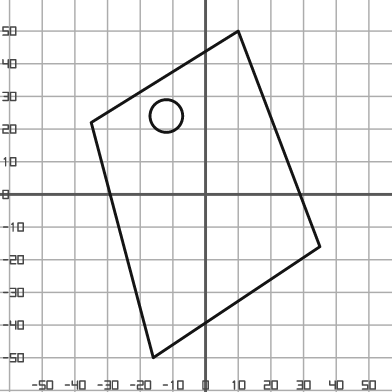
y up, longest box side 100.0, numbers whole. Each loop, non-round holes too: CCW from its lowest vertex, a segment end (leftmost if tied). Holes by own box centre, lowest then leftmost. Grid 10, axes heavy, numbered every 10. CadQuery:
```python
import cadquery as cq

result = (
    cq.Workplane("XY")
    .moveTo(-16.0, -50.0)
    .lineTo(35.0, -16.0)
    .lineTo(10.0, 50.0)
    .lineTo(-35.0, 22.0)
    .close()
    .moveTo(-12.0, 24.0)
    .circle(5.0)
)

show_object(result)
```